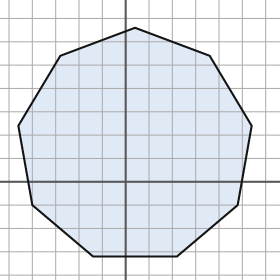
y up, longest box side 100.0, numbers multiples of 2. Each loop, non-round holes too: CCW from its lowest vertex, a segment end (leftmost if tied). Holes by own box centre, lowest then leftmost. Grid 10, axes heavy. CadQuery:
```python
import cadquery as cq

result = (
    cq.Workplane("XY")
    .moveTo(-14.0, -32.0)
    .lineTo(22.0, -32.0)
    .lineTo(48.0, -10.0)
    .lineTo(54.0, 24.0)
    .lineTo(36.0, 54.0)
    .lineTo(4.0, 66.0)
    .lineTo(-28.0, 54.0)
    .lineTo(-46.0, 24.0)
    .lineTo(-40.0, -10.0)
    .close()
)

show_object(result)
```